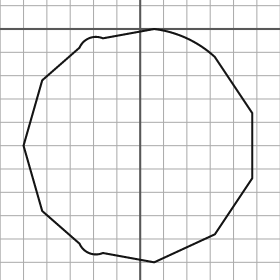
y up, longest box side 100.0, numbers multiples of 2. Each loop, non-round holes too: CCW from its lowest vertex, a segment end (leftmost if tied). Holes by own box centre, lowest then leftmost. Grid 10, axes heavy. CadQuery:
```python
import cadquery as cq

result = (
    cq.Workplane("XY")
    .moveTo(6.0, -100.0)
    .lineTo(32.0, -88.0)
    .lineTo(48.0, -64.0)
    .lineTo(48.0, -36.0)
    .lineTo(32.0, -12.0)
    .threePointArc((20.0, -4.0), (6.0, 0.0))
    .lineTo(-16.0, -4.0)
    .threePointArc((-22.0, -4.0), (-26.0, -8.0))
    .lineTo(-42.0, -22.0)
    .lineTo(-50.0, -50.0)
    .lineTo(-42.0, -78.0)
    .lineTo(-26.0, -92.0)
    .threePointArc((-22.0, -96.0), (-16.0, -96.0))
    .close()
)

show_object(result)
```